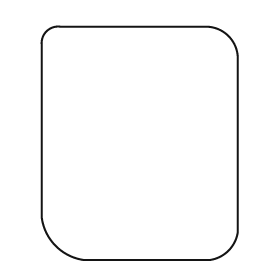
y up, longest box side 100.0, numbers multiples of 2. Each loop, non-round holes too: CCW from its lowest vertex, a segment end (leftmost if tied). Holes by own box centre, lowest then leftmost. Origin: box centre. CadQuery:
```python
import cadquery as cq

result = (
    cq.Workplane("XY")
    .moveTo(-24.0, -50.0)
    .lineTo(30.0, -50.0)
    .threePointArc((38.0, -46.0), (42.0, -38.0))
    .lineTo(42.0, 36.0)
    .threePointArc((38.0, 46.0), (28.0, 50.0))
    .lineTo(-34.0, 50.0)
    .threePointArc((-40.0, 48.0), (-42.0, 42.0))
    .lineTo(-42.0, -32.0)
    .threePointArc((-36.0, -44.0), (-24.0, -50.0))
    .close()
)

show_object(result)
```